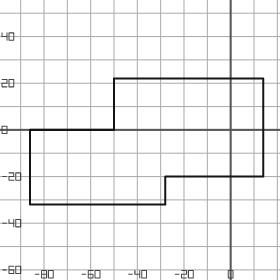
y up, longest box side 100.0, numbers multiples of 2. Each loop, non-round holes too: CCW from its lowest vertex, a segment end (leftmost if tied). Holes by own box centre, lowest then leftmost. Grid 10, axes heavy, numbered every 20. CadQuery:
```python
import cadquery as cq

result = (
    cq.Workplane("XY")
    .moveTo(-86.0, -32.0)
    .lineTo(-28.0, -32.0)
    .lineTo(-28.0, -20.0)
    .lineTo(14.0, -20.0)
    .lineTo(14.0, 22.0)
    .lineTo(-50.0, 22.0)
    .lineTo(-50.0, 0.0)
    .lineTo(-86.0, 0.0)
    .close()
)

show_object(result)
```